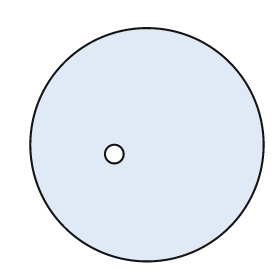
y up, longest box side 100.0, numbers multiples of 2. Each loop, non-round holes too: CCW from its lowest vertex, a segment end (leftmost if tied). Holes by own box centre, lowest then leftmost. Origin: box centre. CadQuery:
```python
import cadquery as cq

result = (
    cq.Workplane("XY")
    .moveTo(0.0, 0.0)
    .circle(50.0)
    .moveTo(-14.0, -4.0)
    .circle(4.0)
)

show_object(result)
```